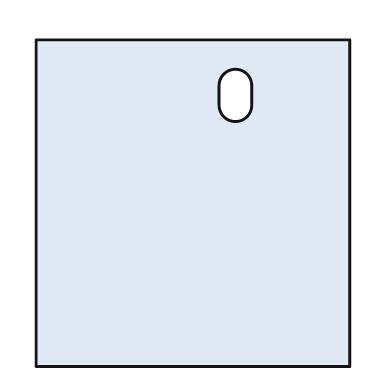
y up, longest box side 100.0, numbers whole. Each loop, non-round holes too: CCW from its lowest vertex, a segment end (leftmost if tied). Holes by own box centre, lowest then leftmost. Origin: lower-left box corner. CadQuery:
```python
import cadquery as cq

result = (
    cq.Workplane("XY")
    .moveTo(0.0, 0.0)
    .lineTo(96.0, 0.0)
    .lineTo(96.0, 100.0)
    .lineTo(0.0, 100.0)
    .close()
    .moveTo(56.0, 80.0)
    .threePointArc((61.0, 75.0), (66.0, 80.0))
    .lineTo(66.0, 86.0)
    .threePointArc((61.0, 91.0), (56.0, 86.0))
    .close()
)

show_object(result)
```